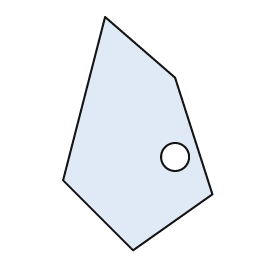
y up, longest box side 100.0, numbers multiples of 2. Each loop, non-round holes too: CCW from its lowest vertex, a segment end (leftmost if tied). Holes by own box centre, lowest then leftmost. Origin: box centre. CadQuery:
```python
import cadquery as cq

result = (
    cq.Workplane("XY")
    .moveTo(-2.0, -50.0)
    .lineTo(32.0, -26.0)
    .lineTo(16.0, 24.0)
    .lineTo(-14.0, 50.0)
    .lineTo(-32.0, -20.0)
    .close()
    .moveTo(16.0, -10.0)
    .circle(6.0)
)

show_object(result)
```